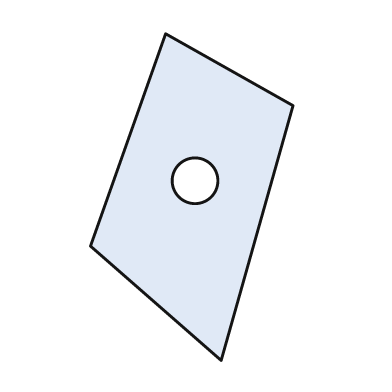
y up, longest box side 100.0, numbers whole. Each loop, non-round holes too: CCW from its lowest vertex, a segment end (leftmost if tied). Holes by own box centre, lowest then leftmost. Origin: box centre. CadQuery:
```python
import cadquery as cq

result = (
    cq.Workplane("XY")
    .moveTo(9.0, -50.0)
    .lineTo(31.0, 28.0)
    .lineTo(-8.0, 50.0)
    .lineTo(-31.0, -15.0)
    .close()
    .moveTo(1.0, 5.0)
    .circle(7.0)
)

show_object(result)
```